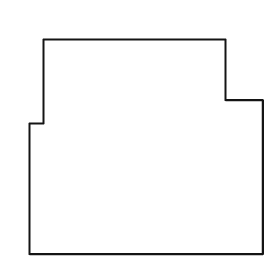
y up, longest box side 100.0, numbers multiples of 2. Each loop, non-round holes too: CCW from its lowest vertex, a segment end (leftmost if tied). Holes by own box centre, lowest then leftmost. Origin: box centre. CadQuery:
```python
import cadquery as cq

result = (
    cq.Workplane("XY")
    .moveTo(-50.0, -46.0)
    .lineTo(50.0, -46.0)
    .lineTo(50.0, 20.0)
    .lineTo(34.0, 20.0)
    .lineTo(34.0, 46.0)
    .lineTo(-44.0, 46.0)
    .lineTo(-44.0, 10.0)
    .lineTo(-50.0, 10.0)
    .close()
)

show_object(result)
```